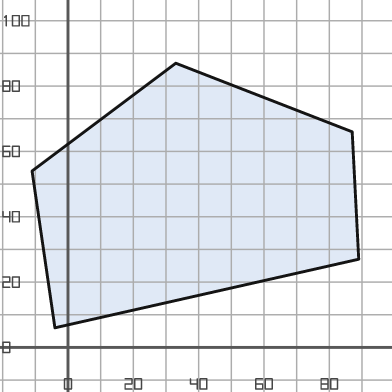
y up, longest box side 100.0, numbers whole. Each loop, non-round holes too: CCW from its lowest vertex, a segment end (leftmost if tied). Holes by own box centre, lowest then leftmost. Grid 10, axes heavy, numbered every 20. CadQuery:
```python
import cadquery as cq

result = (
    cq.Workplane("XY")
    .moveTo(-4.0, 6.0)
    .lineTo(89.0, 27.0)
    .lineTo(87.0, 66.0)
    .lineTo(33.0, 87.0)
    .lineTo(-11.0, 54.0)
    .close()
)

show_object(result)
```